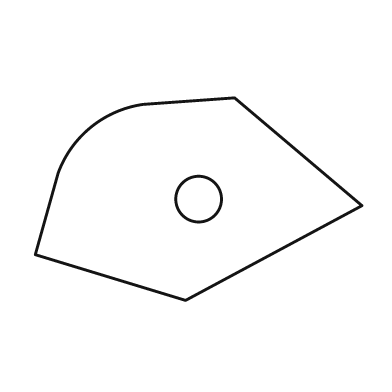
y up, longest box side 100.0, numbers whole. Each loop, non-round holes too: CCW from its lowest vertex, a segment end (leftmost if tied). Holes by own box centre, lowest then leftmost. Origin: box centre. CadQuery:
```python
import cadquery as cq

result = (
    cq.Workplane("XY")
    .moveTo(-4.0, -31.0)
    .lineTo(50.0, -2.0)
    .lineTo(11.0, 31.0)
    .lineTo(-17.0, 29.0)
    .threePointArc((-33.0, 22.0), (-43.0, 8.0))
    .lineTo(-50.0, -17.0)
    .close()
    .moveTo(0.0, 0.0)
    .circle(7.0)
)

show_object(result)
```